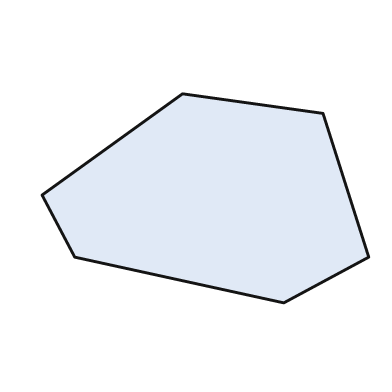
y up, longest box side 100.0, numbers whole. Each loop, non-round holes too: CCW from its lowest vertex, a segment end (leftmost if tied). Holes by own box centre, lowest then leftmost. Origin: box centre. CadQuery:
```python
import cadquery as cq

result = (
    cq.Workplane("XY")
    .moveTo(24.0, -32.0)
    .lineTo(50.0, -18.0)
    .lineTo(36.0, 26.0)
    .lineTo(-7.0, 32.0)
    .lineTo(-50.0, 1.0)
    .lineTo(-40.0, -18.0)
    .close()
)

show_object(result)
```